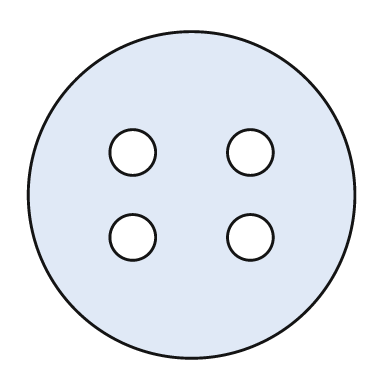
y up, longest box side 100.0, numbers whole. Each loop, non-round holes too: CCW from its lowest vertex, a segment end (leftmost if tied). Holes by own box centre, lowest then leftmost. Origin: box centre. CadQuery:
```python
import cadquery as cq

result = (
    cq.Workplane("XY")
    .moveTo(0.0, 0.0)
    .circle(50.0)
    .moveTo(-18.0, -13.0)
    .circle(7.0)
    .moveTo(18.0, -13.0)
    .circle(7.0)
    .moveTo(-18.0, 13.0)
    .circle(7.0)
    .moveTo(18.0, 13.0)
    .circle(7.0)
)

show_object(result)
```